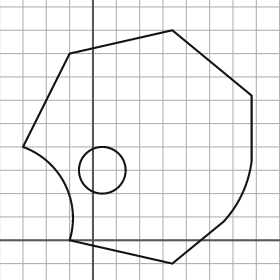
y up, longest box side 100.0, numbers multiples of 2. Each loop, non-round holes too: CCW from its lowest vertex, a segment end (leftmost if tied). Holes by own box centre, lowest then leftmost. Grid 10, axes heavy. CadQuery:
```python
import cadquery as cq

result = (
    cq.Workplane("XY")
    .moveTo(34.0, -10.0)
    .lineTo(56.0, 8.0)
    .threePointArc((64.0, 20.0), (68.0, 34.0))
    .lineTo(68.0, 62.0)
    .lineTo(34.0, 90.0)
    .lineTo(-10.0, 80.0)
    .lineTo(-30.0, 40.0)
    .threePointArc((-12.0, 24.0), (-10.0, 0.0))
    .close()
    .moveTo(4.0, 30.0)
    .circle(10.0)
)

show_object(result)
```